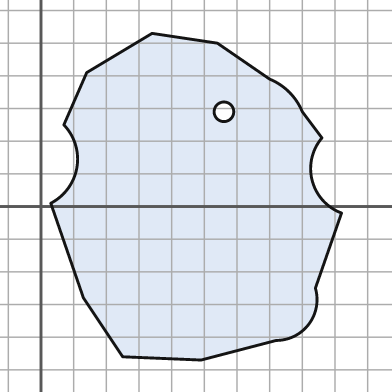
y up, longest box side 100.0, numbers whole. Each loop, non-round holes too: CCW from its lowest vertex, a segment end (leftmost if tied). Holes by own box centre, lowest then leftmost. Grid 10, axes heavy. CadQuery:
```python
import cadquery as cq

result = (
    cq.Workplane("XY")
    .moveTo(49.0, -47.0)
    .lineTo(72.0, -41.0)
    .threePointArc((82.0, -36.0), (84.0, -25.0))
    .lineTo(92.0, -2.0)
    .threePointArc((83.0, 8.0), (86.0, 21.0))
    .lineTo(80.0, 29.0)
    .threePointArc((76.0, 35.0), (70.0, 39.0))
    .lineTo(54.0, 50.0)
    .lineTo(34.0, 53.0)
    .lineTo(14.0, 41.0)
    .lineTo(7.0, 25.0)
    .threePointArc((11.0, 12.0), (3.0, 1.0))
    .lineTo(13.0, -28.0)
    .lineTo(25.0, -46.0)
    .close()
    .moveTo(56.0, 29.0)
    .circle(3.0)
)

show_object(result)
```